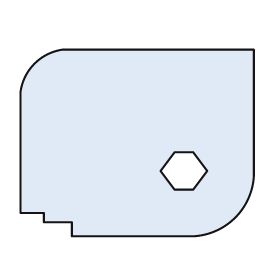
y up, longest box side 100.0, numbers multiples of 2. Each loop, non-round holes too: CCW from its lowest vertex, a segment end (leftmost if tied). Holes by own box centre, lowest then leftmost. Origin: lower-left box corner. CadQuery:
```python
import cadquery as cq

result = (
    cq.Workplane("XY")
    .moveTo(22.0, 0.0)
    .lineTo(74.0, 0.0)
    .threePointArc((92.0, 8.0), (100.0, 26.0))
    .lineTo(100.0, 80.0)
    .lineTo(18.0, 80.0)
    .threePointArc((6.0, 74.0), (0.0, 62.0))
    .lineTo(0.0, 10.0)
    .lineTo(10.0, 10.0)
    .lineTo(10.0, 6.0)
    .lineTo(22.0, 6.0)
    .close()
    .moveTo(66.0, 20.0)
    .lineTo(74.0, 20.0)
    .lineTo(80.0, 28.0)
    .lineTo(74.0, 36.0)
    .lineTo(66.0, 36.0)
    .lineTo(60.0, 28.0)
    .close()
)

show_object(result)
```